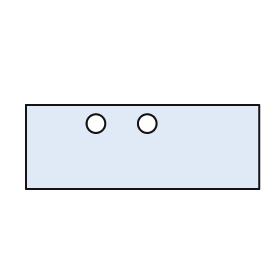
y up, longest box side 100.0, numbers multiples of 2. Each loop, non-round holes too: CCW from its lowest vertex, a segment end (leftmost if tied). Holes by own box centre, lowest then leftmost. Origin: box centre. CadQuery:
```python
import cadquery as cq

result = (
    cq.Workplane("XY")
    .moveTo(-50.0, -18.0)
    .lineTo(50.0, -18.0)
    .lineTo(50.0, 18.0)
    .lineTo(-50.0, 18.0)
    .close()
    .moveTo(-20.0, 10.0)
    .circle(4.0)
    .moveTo(2.0, 10.0)
    .circle(4.0)
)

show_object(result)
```